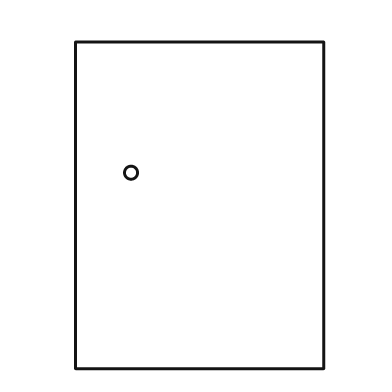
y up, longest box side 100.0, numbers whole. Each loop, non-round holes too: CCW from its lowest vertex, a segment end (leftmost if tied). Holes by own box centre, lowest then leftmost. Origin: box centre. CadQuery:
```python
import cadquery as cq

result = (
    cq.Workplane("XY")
    .moveTo(-38.0, -50.0)
    .lineTo(38.0, -50.0)
    .lineTo(38.0, 50.0)
    .lineTo(-38.0, 50.0)
    .close()
    .moveTo(-21.0, 10.0)
    .circle(2.0)
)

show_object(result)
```